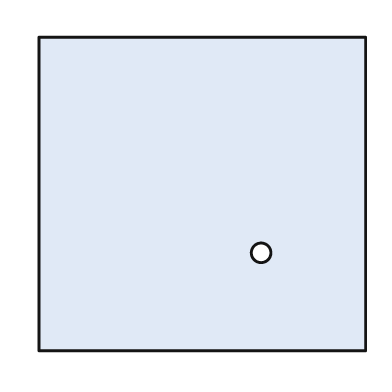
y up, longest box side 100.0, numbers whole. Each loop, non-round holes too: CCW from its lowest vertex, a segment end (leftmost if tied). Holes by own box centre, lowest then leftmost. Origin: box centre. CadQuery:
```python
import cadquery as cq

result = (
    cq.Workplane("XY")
    .moveTo(-50.0, -48.0)
    .lineTo(50.0, -48.0)
    .lineTo(50.0, 48.0)
    .lineTo(-50.0, 48.0)
    .close()
    .moveTo(18.0, -18.0)
    .circle(3.0)
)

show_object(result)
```